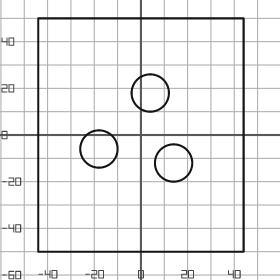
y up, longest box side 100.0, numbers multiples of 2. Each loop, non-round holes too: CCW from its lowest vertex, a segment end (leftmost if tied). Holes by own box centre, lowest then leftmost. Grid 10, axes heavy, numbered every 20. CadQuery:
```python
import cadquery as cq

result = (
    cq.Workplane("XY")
    .moveTo(-44.0, -50.0)
    .lineTo(44.0, -50.0)
    .lineTo(44.0, 50.0)
    .lineTo(-44.0, 50.0)
    .close()
    .moveTo(14.0, -12.0)
    .circle(8.0)
    .moveTo(-18.0, -6.0)
    .circle(8.0)
    .moveTo(4.0, 18.0)
    .circle(8.0)
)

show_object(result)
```